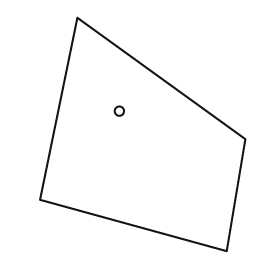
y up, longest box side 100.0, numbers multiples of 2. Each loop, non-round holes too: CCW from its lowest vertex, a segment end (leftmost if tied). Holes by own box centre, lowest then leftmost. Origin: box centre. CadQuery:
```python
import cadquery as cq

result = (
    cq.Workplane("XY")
    .moveTo(36.0, -50.0)
    .lineTo(44.0, -2.0)
    .lineTo(-28.0, 50.0)
    .lineTo(-44.0, -28.0)
    .close()
    .moveTo(-10.0, 10.0)
    .circle(2.0)
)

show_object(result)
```